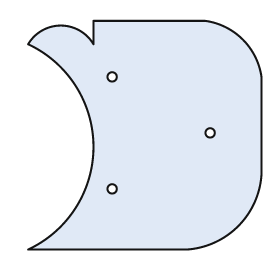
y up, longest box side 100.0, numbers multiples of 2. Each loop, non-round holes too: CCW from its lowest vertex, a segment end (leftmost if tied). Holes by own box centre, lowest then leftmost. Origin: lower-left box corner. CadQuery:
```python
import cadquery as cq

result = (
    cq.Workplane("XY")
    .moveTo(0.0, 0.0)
    .lineTo(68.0, 0.0)
    .threePointArc((90.0, 10.0), (100.0, 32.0))
    .lineTo(100.0, 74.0)
    .threePointArc((92.0, 90.0), (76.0, 98.0))
    .lineTo(28.0, 98.0)
    .lineTo(28.0, 88.0)
    .threePointArc((14.0, 96.0), (0.0, 88.0))
    .threePointArc((28.0, 44.0), (0.0, 0.0))
    .close()
    .moveTo(36.0, 26.0)
    .circle(2.0)
    .moveTo(78.0, 50.0)
    .circle(2.0)
    .moveTo(36.0, 74.0)
    .circle(2.0)
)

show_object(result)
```